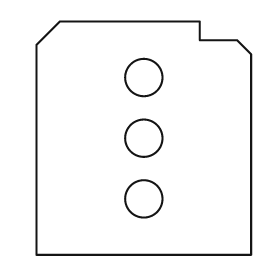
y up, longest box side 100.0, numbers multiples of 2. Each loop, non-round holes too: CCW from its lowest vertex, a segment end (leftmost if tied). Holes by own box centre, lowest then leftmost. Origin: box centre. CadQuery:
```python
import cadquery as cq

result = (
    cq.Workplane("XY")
    .moveTo(-46.0, -50.0)
    .lineTo(46.0, -50.0)
    .lineTo(46.0, 36.0)
    .lineTo(40.0, 42.0)
    .lineTo(24.0, 42.0)
    .lineTo(24.0, 50.0)
    .lineTo(-36.0, 50.0)
    .lineTo(-46.0, 40.0)
    .close()
    .moveTo(0.0, -26.0)
    .circle(8.0)
    .moveTo(0.0, 0.0)
    .circle(8.0)
    .moveTo(0.0, 26.0)
    .circle(8.0)
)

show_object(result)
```